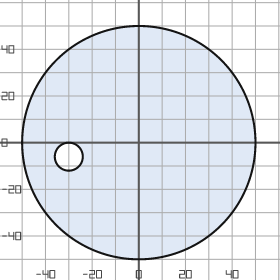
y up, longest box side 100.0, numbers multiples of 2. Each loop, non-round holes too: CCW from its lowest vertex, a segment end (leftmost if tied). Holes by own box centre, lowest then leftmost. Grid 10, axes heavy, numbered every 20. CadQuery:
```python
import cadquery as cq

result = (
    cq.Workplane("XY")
    .moveTo(0.0, 0.0)
    .circle(50.0)
    .moveTo(-30.0, -6.0)
    .circle(6.0)
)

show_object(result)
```